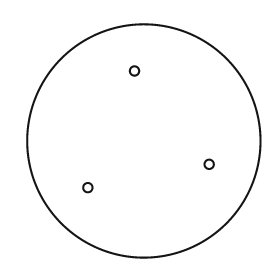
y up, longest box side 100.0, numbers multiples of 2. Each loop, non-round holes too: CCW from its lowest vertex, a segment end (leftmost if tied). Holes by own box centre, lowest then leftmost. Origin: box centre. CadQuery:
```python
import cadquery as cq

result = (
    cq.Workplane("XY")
    .moveTo(0.0, 0.0)
    .circle(50.0)
    .moveTo(-24.0, -20.0)
    .circle(2.0)
    .moveTo(28.0, -10.0)
    .circle(2.0)
    .moveTo(-4.0, 30.0)
    .circle(2.0)
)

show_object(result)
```